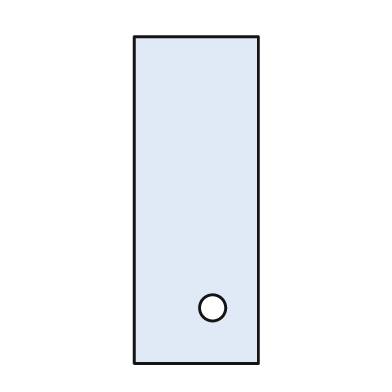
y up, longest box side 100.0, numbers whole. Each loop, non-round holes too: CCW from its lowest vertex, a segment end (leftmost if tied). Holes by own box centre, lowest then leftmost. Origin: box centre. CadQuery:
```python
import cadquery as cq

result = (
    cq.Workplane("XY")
    .moveTo(-19.0, -50.0)
    .lineTo(19.0, -50.0)
    .lineTo(19.0, 50.0)
    .lineTo(-19.0, 50.0)
    .close()
    .moveTo(5.0, -33.0)
    .circle(4.0)
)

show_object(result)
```